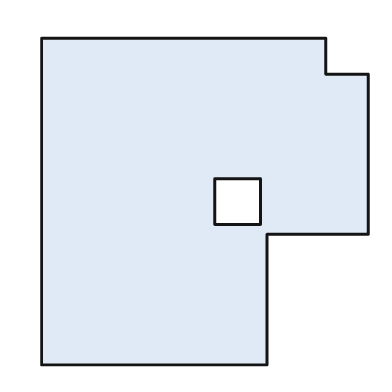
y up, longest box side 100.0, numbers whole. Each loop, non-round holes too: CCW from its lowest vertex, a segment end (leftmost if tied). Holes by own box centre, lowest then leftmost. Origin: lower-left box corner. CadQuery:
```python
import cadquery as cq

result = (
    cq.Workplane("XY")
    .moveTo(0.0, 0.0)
    .lineTo(69.0, 0.0)
    .lineTo(69.0, 40.0)
    .lineTo(100.0, 40.0)
    .lineTo(100.0, 89.0)
    .lineTo(87.0, 89.0)
    .lineTo(87.0, 100.0)
    .lineTo(0.0, 100.0)
    .close()
    .moveTo(53.0, 43.0)
    .lineTo(67.0, 43.0)
    .lineTo(67.0, 57.0)
    .lineTo(53.0, 57.0)
    .close()
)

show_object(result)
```